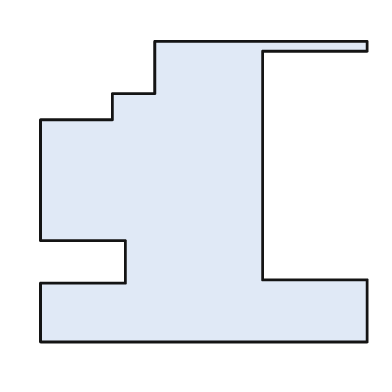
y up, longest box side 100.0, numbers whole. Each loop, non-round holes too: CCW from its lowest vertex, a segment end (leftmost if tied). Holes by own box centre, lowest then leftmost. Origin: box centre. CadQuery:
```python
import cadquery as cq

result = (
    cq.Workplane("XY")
    .moveTo(-50.0, -46.0)
    .lineTo(50.0, -46.0)
    .lineTo(50.0, -27.0)
    .lineTo(18.0, -27.0)
    .lineTo(18.0, 43.0)
    .lineTo(50.0, 43.0)
    .lineTo(50.0, 46.0)
    .lineTo(-15.0, 46.0)
    .lineTo(-15.0, 30.0)
    .lineTo(-28.0, 30.0)
    .lineTo(-28.0, 22.0)
    .lineTo(-50.0, 22.0)
    .lineTo(-50.0, -15.0)
    .lineTo(-24.0, -15.0)
    .lineTo(-24.0, -28.0)
    .lineTo(-50.0, -28.0)
    .close()
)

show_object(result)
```